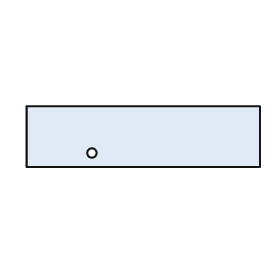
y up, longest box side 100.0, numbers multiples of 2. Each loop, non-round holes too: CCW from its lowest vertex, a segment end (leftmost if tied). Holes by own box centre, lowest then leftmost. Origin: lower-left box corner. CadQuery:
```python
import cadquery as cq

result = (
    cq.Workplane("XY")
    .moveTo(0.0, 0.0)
    .lineTo(100.0, 0.0)
    .lineTo(100.0, 26.0)
    .lineTo(0.0, 26.0)
    .close()
    .moveTo(28.0, 6.0)
    .circle(2.0)
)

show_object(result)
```